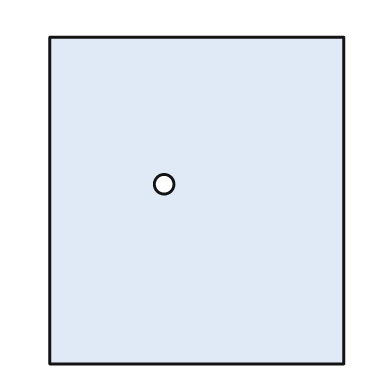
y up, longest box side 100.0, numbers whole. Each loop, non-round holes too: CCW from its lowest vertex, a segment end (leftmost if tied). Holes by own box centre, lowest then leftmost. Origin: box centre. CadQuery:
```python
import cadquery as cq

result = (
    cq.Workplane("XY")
    .moveTo(-45.0, -50.0)
    .lineTo(45.0, -50.0)
    .lineTo(45.0, 50.0)
    .lineTo(-45.0, 50.0)
    .close()
    .moveTo(-10.0, 5.0)
    .circle(3.0)
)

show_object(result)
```